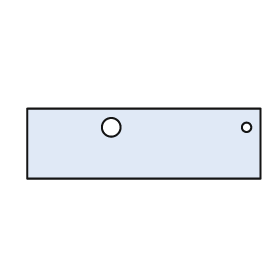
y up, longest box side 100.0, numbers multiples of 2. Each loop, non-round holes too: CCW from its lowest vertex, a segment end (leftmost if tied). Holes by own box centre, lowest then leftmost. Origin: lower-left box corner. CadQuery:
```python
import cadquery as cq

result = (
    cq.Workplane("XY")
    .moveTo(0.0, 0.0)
    .lineTo(100.0, 0.0)
    .lineTo(100.0, 30.0)
    .lineTo(0.0, 30.0)
    .close()
    .moveTo(36.0, 22.0)
    .circle(4.0)
    .moveTo(94.0, 22.0)
    .circle(2.0)
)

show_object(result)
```